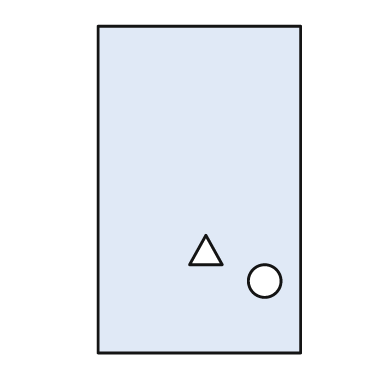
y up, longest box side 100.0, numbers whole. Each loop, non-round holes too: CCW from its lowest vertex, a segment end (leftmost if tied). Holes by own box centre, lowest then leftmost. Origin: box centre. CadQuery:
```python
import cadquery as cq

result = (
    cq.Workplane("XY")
    .moveTo(-31.0, -50.0)
    .lineTo(31.0, -50.0)
    .lineTo(31.0, 50.0)
    .lineTo(-31.0, 50.0)
    .close()
    .moveTo(20.0, -28.0)
    .circle(5.0)
    .moveTo(-3.0, -23.0)
    .lineTo(7.0, -23.0)
    .lineTo(2.0, -14.0)
    .close()
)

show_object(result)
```